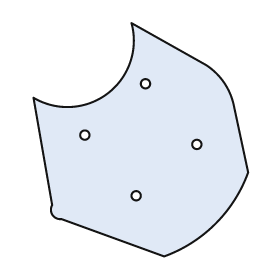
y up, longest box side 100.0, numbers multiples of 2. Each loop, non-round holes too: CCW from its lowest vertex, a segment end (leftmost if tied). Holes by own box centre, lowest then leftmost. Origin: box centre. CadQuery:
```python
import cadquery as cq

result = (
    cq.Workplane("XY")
    .moveTo(10.0, -50.0)
    .threePointArc((32.0, -36.0), (46.0, -14.0))
    .lineTo(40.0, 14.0)
    .threePointArc((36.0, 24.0), (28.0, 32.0))
    .lineTo(-4.0, 50.0)
    .threePointArc((-14.0, 20.0), (-46.0, 18.0))
    .lineTo(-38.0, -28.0)
    .threePointArc((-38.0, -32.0), (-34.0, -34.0))
    .close()
    .moveTo(-2.0, -24.0)
    .circle(2.0)
    .moveTo(24.0, -2.0)
    .circle(2.0)
    .moveTo(-24.0, 2.0)
    .circle(2.0)
    .moveTo(2.0, 24.0)
    .circle(2.0)
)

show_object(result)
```